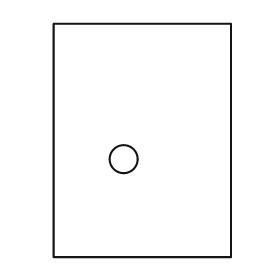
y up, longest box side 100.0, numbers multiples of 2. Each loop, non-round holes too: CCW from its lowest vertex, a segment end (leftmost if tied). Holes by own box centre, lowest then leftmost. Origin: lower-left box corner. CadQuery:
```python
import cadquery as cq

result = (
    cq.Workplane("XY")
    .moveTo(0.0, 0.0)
    .lineTo(76.0, 0.0)
    .lineTo(76.0, 100.0)
    .lineTo(0.0, 100.0)
    .close()
    .moveTo(30.0, 42.0)
    .circle(6.0)
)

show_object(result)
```